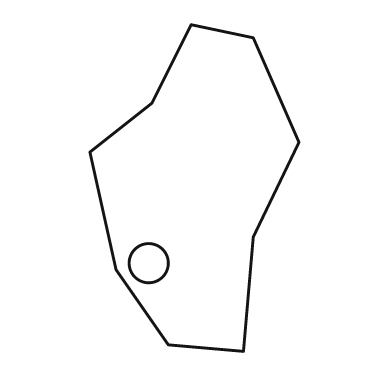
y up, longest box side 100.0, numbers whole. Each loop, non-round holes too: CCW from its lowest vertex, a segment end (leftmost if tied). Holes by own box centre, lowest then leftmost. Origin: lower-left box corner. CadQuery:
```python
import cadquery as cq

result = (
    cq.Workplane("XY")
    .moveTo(47.0, 0.0)
    .lineTo(50.0, 35.0)
    .lineTo(64.0, 64.0)
    .lineTo(50.0, 96.0)
    .lineTo(31.0, 100.0)
    .lineTo(19.0, 76.0)
    .lineTo(0.0, 61.0)
    .lineTo(8.0, 25.0)
    .lineTo(24.0, 2.0)
    .close()
    .moveTo(18.0, 27.0)
    .circle(6.0)
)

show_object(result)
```